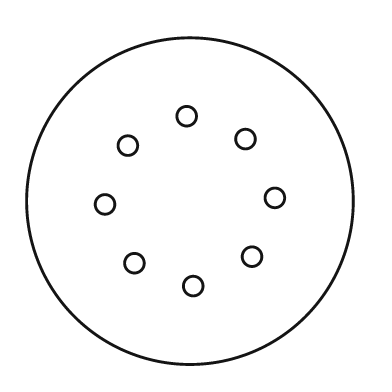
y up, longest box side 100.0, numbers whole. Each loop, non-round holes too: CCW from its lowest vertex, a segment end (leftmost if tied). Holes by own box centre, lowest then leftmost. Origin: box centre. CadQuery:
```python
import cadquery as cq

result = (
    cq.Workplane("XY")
    .moveTo(0.0, 0.0)
    .circle(50.0)
    .moveTo(1.0, -26.0)
    .circle(3.0)
    .moveTo(-17.0, -19.0)
    .circle(3.0)
    .moveTo(19.0, -17.0)
    .circle(3.0)
    .moveTo(-26.0, -1.0)
    .circle(3.0)
    .moveTo(26.0, 1.0)
    .circle(3.0)
    .moveTo(-19.0, 17.0)
    .circle(3.0)
    .moveTo(17.0, 19.0)
    .circle(3.0)
    .moveTo(-1.0, 26.0)
    .circle(3.0)
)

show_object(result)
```